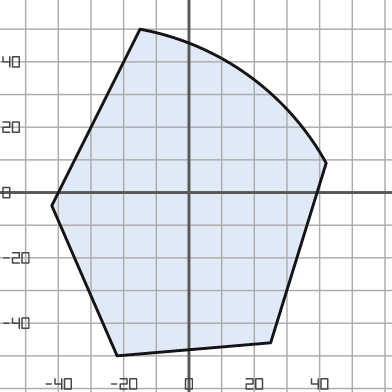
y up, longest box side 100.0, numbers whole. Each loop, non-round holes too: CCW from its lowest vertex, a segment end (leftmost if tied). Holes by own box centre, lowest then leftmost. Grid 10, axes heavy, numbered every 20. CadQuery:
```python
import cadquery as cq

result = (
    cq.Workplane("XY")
    .moveTo(-22.0, -50.0)
    .lineTo(25.0, -46.0)
    .lineTo(42.0, 9.0)
    .threePointArc((18.0, 36.0), (-15.0, 50.0))
    .lineTo(-42.0, -4.0)
    .close()
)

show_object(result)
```